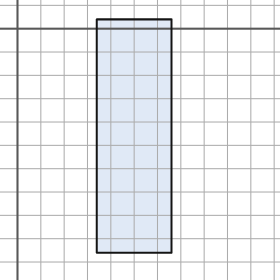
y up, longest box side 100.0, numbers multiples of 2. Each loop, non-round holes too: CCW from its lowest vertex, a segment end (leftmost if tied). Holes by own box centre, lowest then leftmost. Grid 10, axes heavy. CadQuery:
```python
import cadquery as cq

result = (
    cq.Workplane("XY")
    .moveTo(34.0, -96.0)
    .lineTo(66.0, -96.0)
    .lineTo(66.0, 4.0)
    .lineTo(34.0, 4.0)
    .close()
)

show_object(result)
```